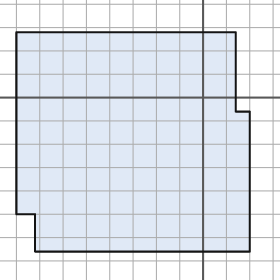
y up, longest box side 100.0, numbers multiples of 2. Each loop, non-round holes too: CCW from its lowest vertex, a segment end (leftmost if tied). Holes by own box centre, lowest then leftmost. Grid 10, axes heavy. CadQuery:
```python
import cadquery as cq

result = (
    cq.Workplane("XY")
    .moveTo(-72.0, -66.0)
    .lineTo(20.0, -66.0)
    .lineTo(20.0, -6.0)
    .lineTo(14.0, -6.0)
    .lineTo(14.0, 28.0)
    .lineTo(-80.0, 28.0)
    .lineTo(-80.0, -50.0)
    .lineTo(-72.0, -50.0)
    .close()
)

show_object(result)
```